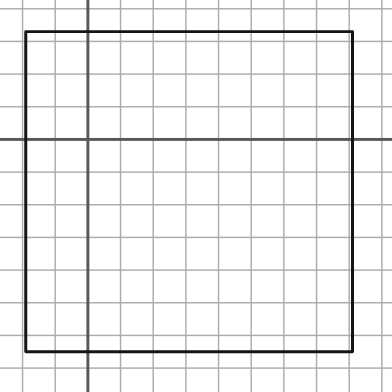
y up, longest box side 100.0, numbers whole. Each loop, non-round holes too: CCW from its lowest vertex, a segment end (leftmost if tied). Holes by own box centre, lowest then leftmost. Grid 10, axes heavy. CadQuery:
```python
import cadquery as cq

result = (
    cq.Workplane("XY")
    .moveTo(-19.0, -65.0)
    .lineTo(81.0, -65.0)
    .lineTo(81.0, 33.0)
    .lineTo(-19.0, 33.0)
    .close()
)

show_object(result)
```